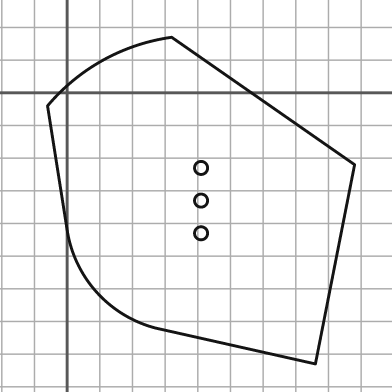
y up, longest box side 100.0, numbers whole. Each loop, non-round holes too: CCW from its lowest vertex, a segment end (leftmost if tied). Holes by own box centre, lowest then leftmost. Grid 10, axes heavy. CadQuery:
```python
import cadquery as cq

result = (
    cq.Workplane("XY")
    .moveTo(76.0, -83.0)
    .lineTo(88.0, -22.0)
    .lineTo(32.0, 17.0)
    .threePointArc((11.0, 10.0), (-6.0, -4.0))
    .lineTo(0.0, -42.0)
    .threePointArc((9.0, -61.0), (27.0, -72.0))
    .close()
    .moveTo(41.0, -43.0)
    .circle(2.0)
    .moveTo(41.0, -33.0)
    .circle(2.0)
    .moveTo(41.0, -23.0)
    .circle(2.0)
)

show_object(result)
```